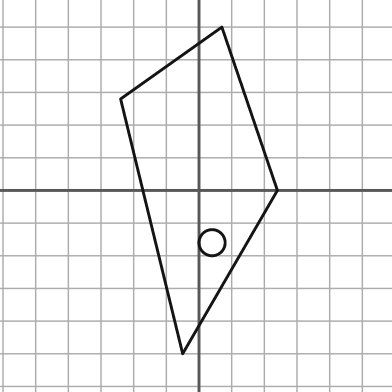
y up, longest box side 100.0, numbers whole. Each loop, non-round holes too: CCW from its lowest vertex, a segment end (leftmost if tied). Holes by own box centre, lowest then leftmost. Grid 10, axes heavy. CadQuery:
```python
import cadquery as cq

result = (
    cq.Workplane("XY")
    .moveTo(-5.0, -50.0)
    .lineTo(24.0, 0.0)
    .lineTo(7.0, 50.0)
    .lineTo(-24.0, 28.0)
    .close()
    .moveTo(4.0, -16.0)
    .circle(4.0)
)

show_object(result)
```